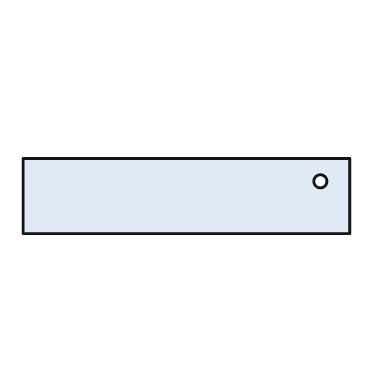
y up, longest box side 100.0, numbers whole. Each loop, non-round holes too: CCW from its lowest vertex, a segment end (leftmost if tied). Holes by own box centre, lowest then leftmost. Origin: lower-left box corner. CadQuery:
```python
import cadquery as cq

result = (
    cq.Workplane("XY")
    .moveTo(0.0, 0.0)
    .lineTo(100.0, 0.0)
    .lineTo(100.0, 23.0)
    .lineTo(0.0, 23.0)
    .close()
    .moveTo(91.0, 16.0)
    .circle(2.0)
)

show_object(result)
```